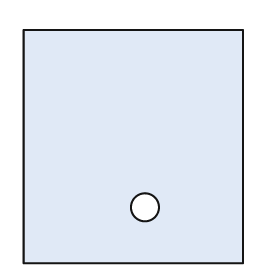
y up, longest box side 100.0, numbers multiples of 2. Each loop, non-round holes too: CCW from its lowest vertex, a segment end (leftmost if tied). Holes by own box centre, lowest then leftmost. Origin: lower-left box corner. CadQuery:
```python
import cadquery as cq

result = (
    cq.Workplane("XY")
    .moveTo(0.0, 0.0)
    .lineTo(94.0, 0.0)
    .lineTo(94.0, 100.0)
    .lineTo(0.0, 100.0)
    .close()
    .moveTo(52.0, 24.0)
    .circle(6.0)
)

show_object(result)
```